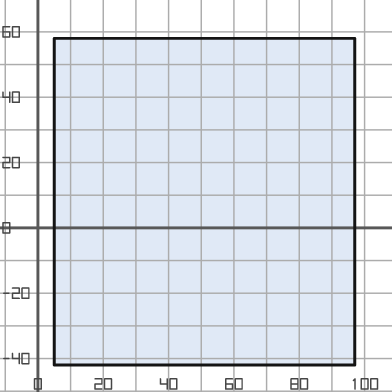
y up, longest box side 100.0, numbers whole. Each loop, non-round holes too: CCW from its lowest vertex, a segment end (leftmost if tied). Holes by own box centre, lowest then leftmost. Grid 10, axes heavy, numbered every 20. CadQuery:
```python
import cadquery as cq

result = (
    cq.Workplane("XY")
    .moveTo(5.0, -42.0)
    .lineTo(97.0, -42.0)
    .lineTo(97.0, 58.0)
    .lineTo(5.0, 58.0)
    .close()
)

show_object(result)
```